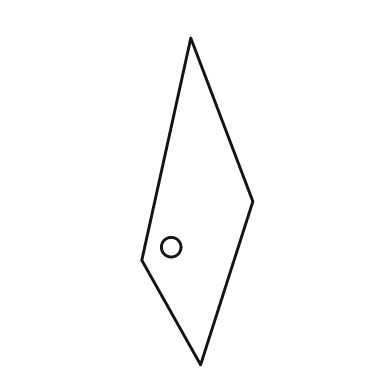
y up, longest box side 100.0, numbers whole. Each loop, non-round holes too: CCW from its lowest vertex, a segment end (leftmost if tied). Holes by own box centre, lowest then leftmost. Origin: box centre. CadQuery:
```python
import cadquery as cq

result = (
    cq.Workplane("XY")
    .moveTo(1.0, -50.0)
    .lineTo(17.0, 0.0)
    .lineTo(-2.0, 50.0)
    .lineTo(-17.0, -18.0)
    .close()
    .moveTo(-8.0, -14.0)
    .circle(3.0)
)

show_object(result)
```